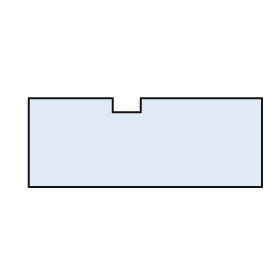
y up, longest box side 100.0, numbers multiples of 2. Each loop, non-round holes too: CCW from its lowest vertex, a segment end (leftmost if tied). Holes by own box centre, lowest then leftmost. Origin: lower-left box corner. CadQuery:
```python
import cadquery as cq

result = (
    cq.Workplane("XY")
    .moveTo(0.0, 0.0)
    .lineTo(100.0, 0.0)
    .lineTo(100.0, 38.0)
    .lineTo(48.0, 38.0)
    .lineTo(48.0, 32.0)
    .lineTo(36.0, 32.0)
    .lineTo(36.0, 38.0)
    .lineTo(0.0, 38.0)
    .close()
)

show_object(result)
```